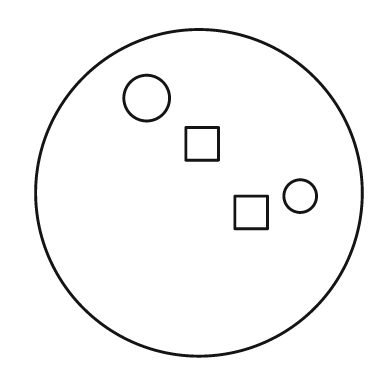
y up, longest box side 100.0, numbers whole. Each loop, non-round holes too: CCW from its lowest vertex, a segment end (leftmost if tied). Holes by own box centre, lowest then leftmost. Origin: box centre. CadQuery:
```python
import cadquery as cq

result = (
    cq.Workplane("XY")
    .moveTo(0.0, 0.0)
    .circle(50.0)
    .moveTo(11.0, -11.0)
    .lineTo(21.0, -11.0)
    .lineTo(21.0, -1.0)
    .lineTo(11.0, -1.0)
    .close()
    .moveTo(31.0, -1.0)
    .circle(5.0)
    .moveTo(-4.0, 10.0)
    .lineTo(6.0, 10.0)
    .lineTo(6.0, 20.0)
    .lineTo(-4.0, 20.0)
    .close()
    .moveTo(-16.0, 29.0)
    .circle(7.0)
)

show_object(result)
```